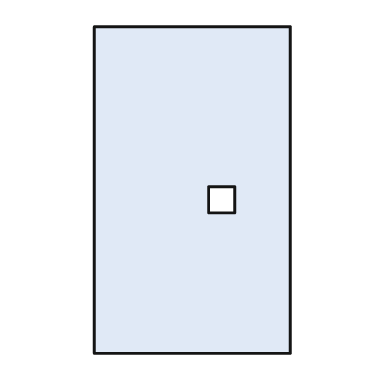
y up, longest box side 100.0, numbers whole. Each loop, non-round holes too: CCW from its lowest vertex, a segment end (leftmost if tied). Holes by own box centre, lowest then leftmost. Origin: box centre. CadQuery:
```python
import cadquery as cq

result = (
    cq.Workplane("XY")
    .moveTo(-30.0, -50.0)
    .lineTo(30.0, -50.0)
    .lineTo(30.0, 50.0)
    .lineTo(-30.0, 50.0)
    .close()
    .moveTo(5.0, -7.0)
    .lineTo(13.0, -7.0)
    .lineTo(13.0, 1.0)
    .lineTo(5.0, 1.0)
    .close()
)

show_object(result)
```